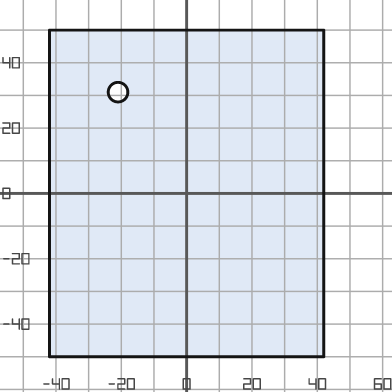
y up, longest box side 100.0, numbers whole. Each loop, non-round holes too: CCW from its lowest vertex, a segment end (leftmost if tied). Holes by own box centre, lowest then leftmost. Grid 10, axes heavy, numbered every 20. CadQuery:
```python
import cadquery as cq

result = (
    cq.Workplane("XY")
    .moveTo(-42.0, -50.0)
    .lineTo(42.0, -50.0)
    .lineTo(42.0, 50.0)
    .lineTo(-42.0, 50.0)
    .close()
    .moveTo(-21.0, 31.0)
    .circle(3.0)
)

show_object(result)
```